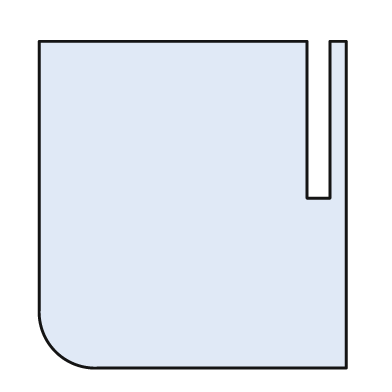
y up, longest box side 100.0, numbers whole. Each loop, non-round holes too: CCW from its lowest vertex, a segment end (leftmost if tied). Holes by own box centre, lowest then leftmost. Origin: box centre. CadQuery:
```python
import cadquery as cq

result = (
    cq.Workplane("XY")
    .moveTo(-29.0, -50.0)
    .lineTo(47.0, -50.0)
    .lineTo(47.0, 50.0)
    .lineTo(42.0, 50.0)
    .lineTo(42.0, 2.0)
    .lineTo(35.0, 2.0)
    .lineTo(35.0, 50.0)
    .lineTo(-47.0, 50.0)
    .lineTo(-47.0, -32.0)
    .threePointArc((-42.0, -45.0), (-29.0, -50.0))
    .close()
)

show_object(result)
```